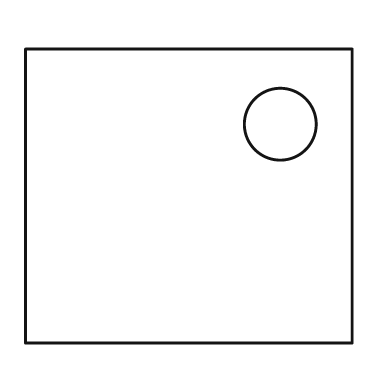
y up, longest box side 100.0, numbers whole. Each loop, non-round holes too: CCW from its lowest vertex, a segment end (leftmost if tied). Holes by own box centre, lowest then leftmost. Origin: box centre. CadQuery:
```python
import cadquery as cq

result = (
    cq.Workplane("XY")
    .moveTo(-50.0, -45.0)
    .lineTo(50.0, -45.0)
    .lineTo(50.0, 45.0)
    .lineTo(-50.0, 45.0)
    .close()
    .moveTo(28.0, 22.0)
    .circle(11.0)
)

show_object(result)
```